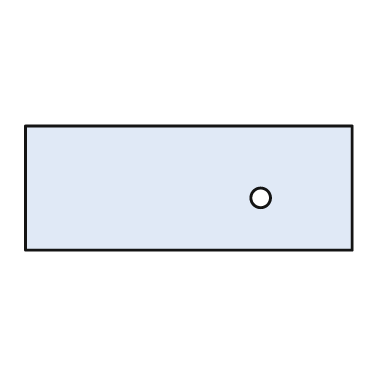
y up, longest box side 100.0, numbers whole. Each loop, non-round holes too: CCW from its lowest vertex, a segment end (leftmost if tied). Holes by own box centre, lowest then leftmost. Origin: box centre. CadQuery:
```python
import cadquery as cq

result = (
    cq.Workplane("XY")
    .moveTo(-50.0, -19.0)
    .lineTo(50.0, -19.0)
    .lineTo(50.0, 19.0)
    .lineTo(-50.0, 19.0)
    .close()
    .moveTo(22.0, -3.0)
    .circle(3.0)
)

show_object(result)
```